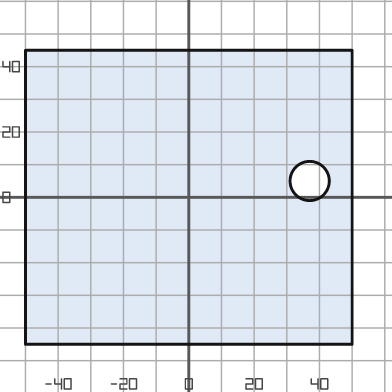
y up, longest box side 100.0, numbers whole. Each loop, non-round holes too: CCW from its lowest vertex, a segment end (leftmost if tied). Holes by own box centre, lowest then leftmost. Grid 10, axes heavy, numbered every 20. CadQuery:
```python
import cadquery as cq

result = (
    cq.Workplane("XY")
    .moveTo(-50.0, -45.0)
    .lineTo(50.0, -45.0)
    .lineTo(50.0, 45.0)
    .lineTo(-50.0, 45.0)
    .close()
    .moveTo(37.0, 5.0)
    .circle(6.0)
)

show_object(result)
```